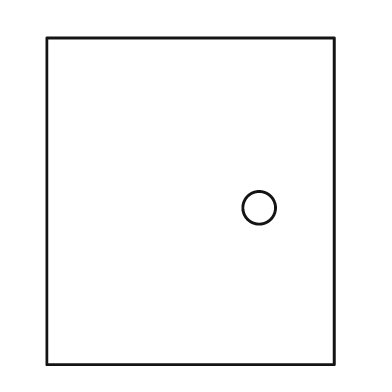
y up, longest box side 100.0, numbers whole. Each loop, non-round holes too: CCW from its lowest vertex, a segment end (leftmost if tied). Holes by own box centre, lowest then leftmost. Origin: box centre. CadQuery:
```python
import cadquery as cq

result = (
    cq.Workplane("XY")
    .moveTo(-44.0, -50.0)
    .lineTo(44.0, -50.0)
    .lineTo(44.0, 50.0)
    .lineTo(-44.0, 50.0)
    .close()
    .moveTo(21.0, -2.0)
    .circle(5.0)
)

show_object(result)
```